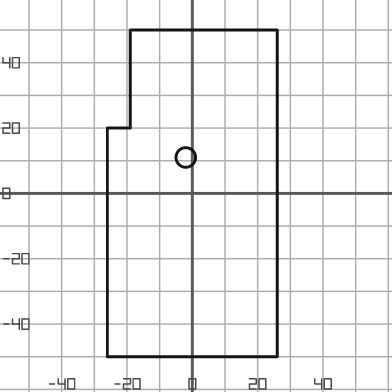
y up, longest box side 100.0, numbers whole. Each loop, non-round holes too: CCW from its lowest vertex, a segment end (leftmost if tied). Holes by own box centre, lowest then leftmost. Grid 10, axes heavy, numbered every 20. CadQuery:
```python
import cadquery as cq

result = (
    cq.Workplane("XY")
    .moveTo(-26.0, -50.0)
    .lineTo(26.0, -50.0)
    .lineTo(26.0, 50.0)
    .lineTo(-19.0, 50.0)
    .lineTo(-19.0, 20.0)
    .lineTo(-26.0, 20.0)
    .close()
    .moveTo(-2.0, 11.0)
    .circle(3.0)
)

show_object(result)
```